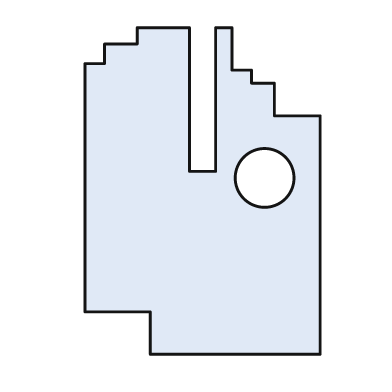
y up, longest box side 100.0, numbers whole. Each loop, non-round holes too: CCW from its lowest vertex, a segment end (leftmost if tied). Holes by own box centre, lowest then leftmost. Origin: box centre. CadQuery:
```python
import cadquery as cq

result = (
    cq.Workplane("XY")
    .moveTo(-16.0, -50.0)
    .lineTo(36.0, -50.0)
    .lineTo(36.0, 23.0)
    .lineTo(22.0, 23.0)
    .lineTo(22.0, 33.0)
    .lineTo(15.0, 33.0)
    .lineTo(15.0, 37.0)
    .lineTo(9.0, 37.0)
    .lineTo(9.0, 50.0)
    .lineTo(4.0, 50.0)
    .lineTo(4.0, 6.0)
    .lineTo(-4.0, 6.0)
    .lineTo(-4.0, 50.0)
    .lineTo(-20.0, 50.0)
    .lineTo(-20.0, 45.0)
    .lineTo(-30.0, 45.0)
    .lineTo(-30.0, 39.0)
    .lineTo(-36.0, 39.0)
    .lineTo(-36.0, -37.0)
    .lineTo(-16.0, -37.0)
    .close()
    .moveTo(19.0, 4.0)
    .circle(9.0)
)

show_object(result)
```